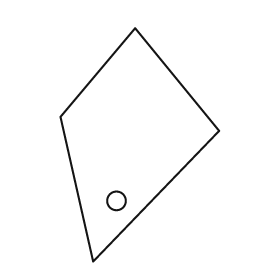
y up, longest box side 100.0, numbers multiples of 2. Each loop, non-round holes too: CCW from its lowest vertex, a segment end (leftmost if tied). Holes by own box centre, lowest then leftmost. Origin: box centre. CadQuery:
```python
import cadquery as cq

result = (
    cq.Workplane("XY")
    .moveTo(-20.0, -50.0)
    .lineTo(34.0, 6.0)
    .lineTo(-2.0, 50.0)
    .lineTo(-34.0, 12.0)
    .close()
    .moveTo(-10.0, -24.0)
    .circle(4.0)
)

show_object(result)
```